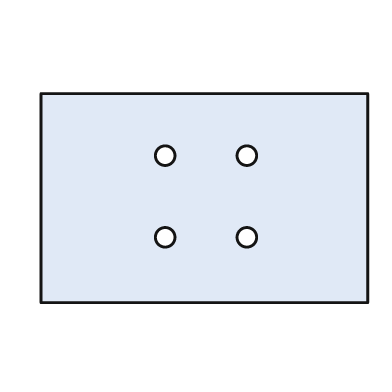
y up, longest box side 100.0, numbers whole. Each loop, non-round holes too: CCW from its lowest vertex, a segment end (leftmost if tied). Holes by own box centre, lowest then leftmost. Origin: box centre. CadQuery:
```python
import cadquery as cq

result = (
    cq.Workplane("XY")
    .moveTo(-50.0, -32.0)
    .lineTo(50.0, -32.0)
    .lineTo(50.0, 32.0)
    .lineTo(-50.0, 32.0)
    .close()
    .moveTo(-12.0, -12.0)
    .circle(3.0)
    .moveTo(13.0, -12.0)
    .circle(3.0)
    .moveTo(-12.0, 13.0)
    .circle(3.0)
    .moveTo(13.0, 13.0)
    .circle(3.0)
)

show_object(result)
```